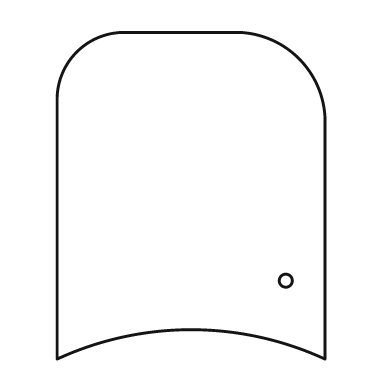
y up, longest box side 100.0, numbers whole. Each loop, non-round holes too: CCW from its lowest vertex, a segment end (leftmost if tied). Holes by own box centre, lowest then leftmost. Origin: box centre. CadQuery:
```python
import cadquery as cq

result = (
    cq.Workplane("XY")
    .moveTo(-41.0, -50.0)
    .threePointArc((0.0, -41.0), (41.0, -50.0))
    .lineTo(41.0, 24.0)
    .threePointArc((33.0, 42.0), (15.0, 50.0))
    .lineTo(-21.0, 50.0)
    .threePointArc((-35.0, 44.0), (-41.0, 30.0))
    .close()
    .moveTo(29.0, -26.0)
    .circle(2.0)
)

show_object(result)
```